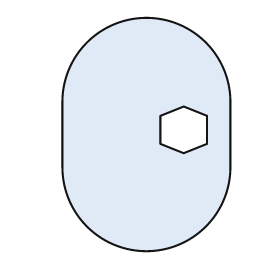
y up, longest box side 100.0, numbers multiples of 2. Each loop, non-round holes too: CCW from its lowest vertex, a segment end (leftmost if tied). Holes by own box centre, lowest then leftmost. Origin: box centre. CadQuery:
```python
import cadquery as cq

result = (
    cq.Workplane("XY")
    .moveTo(-36.0, -14.0)
    .threePointArc((0.0, -50.0), (36.0, -14.0))
    .lineTo(36.0, 14.0)
    .threePointArc((0.0, 50.0), (-36.0, 14.0))
    .close()
    .moveTo(16.0, -8.0)
    .lineTo(26.0, -4.0)
    .lineTo(26.0, 8.0)
    .lineTo(16.0, 12.0)
    .lineTo(6.0, 8.0)
    .lineTo(6.0, -4.0)
    .close()
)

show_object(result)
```